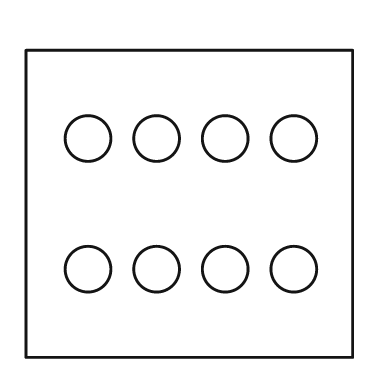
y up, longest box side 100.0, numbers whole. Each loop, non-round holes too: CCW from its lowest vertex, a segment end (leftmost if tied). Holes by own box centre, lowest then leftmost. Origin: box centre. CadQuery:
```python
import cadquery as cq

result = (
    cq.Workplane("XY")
    .moveTo(-50.0, -47.0)
    .lineTo(50.0, -47.0)
    .lineTo(50.0, 47.0)
    .lineTo(-50.0, 47.0)
    .close()
    .moveTo(-31.0, -20.0)
    .circle(7.0)
    .moveTo(-10.0, -20.0)
    .circle(7.0)
    .moveTo(11.0, -20.0)
    .circle(7.0)
    .moveTo(32.0, -20.0)
    .circle(7.0)
    .moveTo(-31.0, 20.0)
    .circle(7.0)
    .moveTo(-10.0, 20.0)
    .circle(7.0)
    .moveTo(11.0, 20.0)
    .circle(7.0)
    .moveTo(32.0, 20.0)
    .circle(7.0)
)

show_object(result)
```